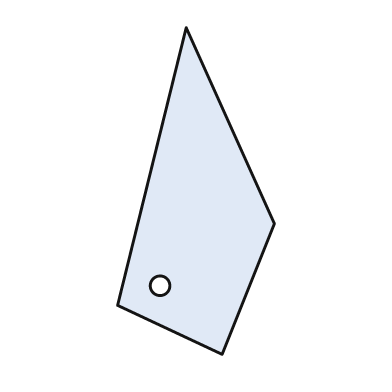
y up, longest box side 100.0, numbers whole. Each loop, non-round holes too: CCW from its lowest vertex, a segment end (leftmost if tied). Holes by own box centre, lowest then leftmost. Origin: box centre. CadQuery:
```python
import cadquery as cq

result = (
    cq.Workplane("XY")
    .moveTo(8.0, -50.0)
    .lineTo(24.0, -10.0)
    .lineTo(-3.0, 50.0)
    .lineTo(-24.0, -35.0)
    .close()
    .moveTo(-11.0, -29.0)
    .circle(3.0)
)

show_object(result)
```